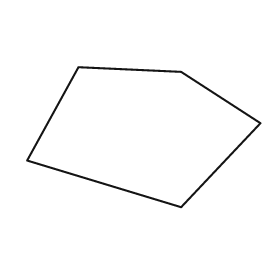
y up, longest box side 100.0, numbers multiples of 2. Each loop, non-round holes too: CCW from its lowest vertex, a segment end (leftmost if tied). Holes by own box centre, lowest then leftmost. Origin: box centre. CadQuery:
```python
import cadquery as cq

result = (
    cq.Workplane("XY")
    .moveTo(16.0, -30.0)
    .lineTo(50.0, 6.0)
    .lineTo(16.0, 28.0)
    .lineTo(-28.0, 30.0)
    .lineTo(-50.0, -10.0)
    .close()
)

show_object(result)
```